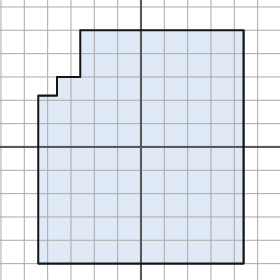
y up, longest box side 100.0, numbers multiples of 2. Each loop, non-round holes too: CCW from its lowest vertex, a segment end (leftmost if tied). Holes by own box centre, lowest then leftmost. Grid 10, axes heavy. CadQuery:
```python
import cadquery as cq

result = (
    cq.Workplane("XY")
    .moveTo(-44.0, -50.0)
    .lineTo(44.0, -50.0)
    .lineTo(44.0, 50.0)
    .lineTo(-26.0, 50.0)
    .lineTo(-26.0, 30.0)
    .lineTo(-36.0, 30.0)
    .lineTo(-36.0, 22.0)
    .lineTo(-44.0, 22.0)
    .close()
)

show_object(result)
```